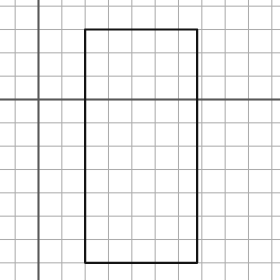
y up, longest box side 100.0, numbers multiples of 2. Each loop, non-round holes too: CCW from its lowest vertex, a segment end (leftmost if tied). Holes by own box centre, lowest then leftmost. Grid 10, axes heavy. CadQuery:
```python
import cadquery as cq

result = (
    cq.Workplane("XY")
    .moveTo(20.0, -70.0)
    .lineTo(68.0, -70.0)
    .lineTo(68.0, 30.0)
    .lineTo(20.0, 30.0)
    .close()
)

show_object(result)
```